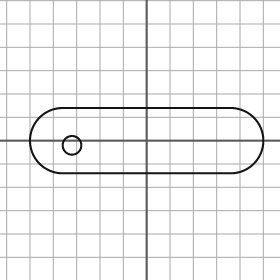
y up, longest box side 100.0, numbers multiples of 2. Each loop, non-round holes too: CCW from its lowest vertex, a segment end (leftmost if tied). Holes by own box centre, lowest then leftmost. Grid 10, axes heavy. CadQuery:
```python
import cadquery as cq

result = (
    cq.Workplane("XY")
    .moveTo(-36.0, -14.0)
    .lineTo(36.0, -14.0)
    .threePointArc((50.0, 0.0), (36.0, 14.0))
    .lineTo(-36.0, 14.0)
    .threePointArc((-50.0, 0.0), (-36.0, -14.0))
    .close()
    .moveTo(-32.0, -2.0)
    .circle(4.0)
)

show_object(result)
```